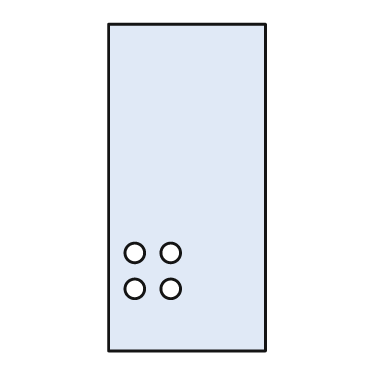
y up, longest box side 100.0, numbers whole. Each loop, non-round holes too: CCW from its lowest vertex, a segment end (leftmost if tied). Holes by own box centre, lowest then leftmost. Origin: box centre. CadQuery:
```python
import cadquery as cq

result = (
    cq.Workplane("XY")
    .moveTo(-24.0, -50.0)
    .lineTo(24.0, -50.0)
    .lineTo(24.0, 50.0)
    .lineTo(-24.0, 50.0)
    .close()
    .moveTo(-16.0, -31.0)
    .circle(3.0)
    .moveTo(-5.0, -31.0)
    .circle(3.0)
    .moveTo(-16.0, -20.0)
    .circle(3.0)
    .moveTo(-5.0, -20.0)
    .circle(3.0)
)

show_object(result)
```